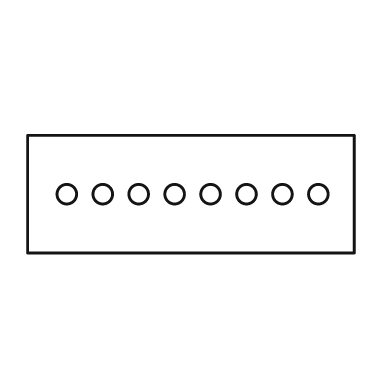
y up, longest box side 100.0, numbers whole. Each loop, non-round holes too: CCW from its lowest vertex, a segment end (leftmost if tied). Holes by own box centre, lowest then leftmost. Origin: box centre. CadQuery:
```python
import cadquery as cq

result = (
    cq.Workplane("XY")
    .moveTo(-50.0, -18.0)
    .lineTo(50.0, -18.0)
    .lineTo(50.0, 18.0)
    .lineTo(-50.0, 18.0)
    .close()
    .moveTo(-38.0, 0.0)
    .circle(3.0)
    .moveTo(-27.0, 0.0)
    .circle(3.0)
    .moveTo(-16.0, 0.0)
    .circle(3.0)
    .moveTo(-5.0, 0.0)
    .circle(3.0)
    .moveTo(6.0, 0.0)
    .circle(3.0)
    .moveTo(17.0, 0.0)
    .circle(3.0)
    .moveTo(28.0, 0.0)
    .circle(3.0)
    .moveTo(39.0, 0.0)
    .circle(3.0)
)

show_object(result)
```